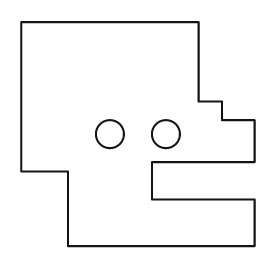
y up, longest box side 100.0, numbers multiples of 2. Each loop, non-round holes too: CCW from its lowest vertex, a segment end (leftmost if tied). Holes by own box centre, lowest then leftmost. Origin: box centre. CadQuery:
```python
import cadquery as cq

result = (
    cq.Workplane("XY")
    .moveTo(-30.0, -48.0)
    .lineTo(50.0, -48.0)
    .lineTo(50.0, -28.0)
    .lineTo(6.0, -28.0)
    .lineTo(6.0, -12.0)
    .lineTo(50.0, -12.0)
    .lineTo(50.0, 6.0)
    .lineTo(36.0, 6.0)
    .lineTo(36.0, 14.0)
    .lineTo(26.0, 14.0)
    .lineTo(26.0, 48.0)
    .lineTo(-50.0, 48.0)
    .lineTo(-50.0, -16.0)
    .lineTo(-30.0, -16.0)
    .close()
    .moveTo(-12.0, 0.0)
    .circle(6.0)
    .moveTo(12.0, 0.0)
    .circle(6.0)
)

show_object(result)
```